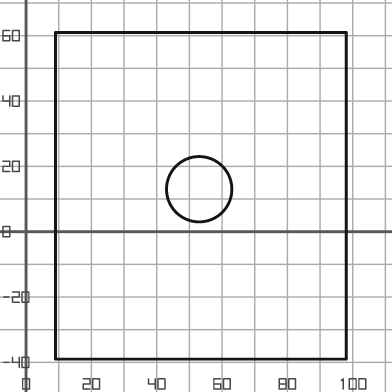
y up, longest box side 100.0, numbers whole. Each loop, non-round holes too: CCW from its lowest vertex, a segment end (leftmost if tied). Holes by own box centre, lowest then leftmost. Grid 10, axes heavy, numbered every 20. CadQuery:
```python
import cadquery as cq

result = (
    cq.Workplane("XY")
    .moveTo(9.0, -39.0)
    .lineTo(98.0, -39.0)
    .lineTo(98.0, 61.0)
    .lineTo(9.0, 61.0)
    .close()
    .moveTo(53.0, 13.0)
    .circle(10.0)
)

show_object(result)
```